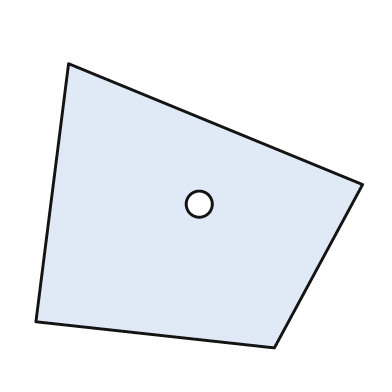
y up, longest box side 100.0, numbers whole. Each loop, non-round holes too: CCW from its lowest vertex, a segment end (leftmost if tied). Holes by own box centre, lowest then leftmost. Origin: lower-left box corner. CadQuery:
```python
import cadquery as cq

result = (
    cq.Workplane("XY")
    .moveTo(73.0, 0.0)
    .lineTo(100.0, 50.0)
    .lineTo(10.0, 87.0)
    .lineTo(0.0, 8.0)
    .close()
    .moveTo(50.0, 44.0)
    .circle(4.0)
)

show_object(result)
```